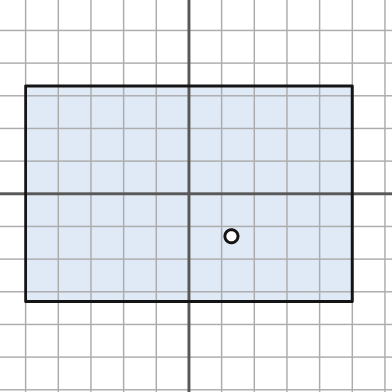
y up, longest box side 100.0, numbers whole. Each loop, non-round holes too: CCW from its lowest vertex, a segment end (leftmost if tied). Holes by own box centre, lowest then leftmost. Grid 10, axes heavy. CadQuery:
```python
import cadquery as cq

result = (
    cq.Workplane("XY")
    .moveTo(-50.0, -33.0)
    .lineTo(50.0, -33.0)
    .lineTo(50.0, 33.0)
    .lineTo(-50.0, 33.0)
    .close()
    .moveTo(13.0, -13.0)
    .circle(2.0)
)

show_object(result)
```